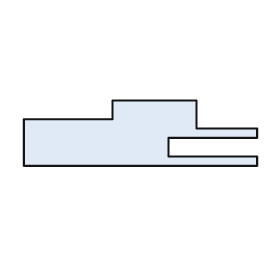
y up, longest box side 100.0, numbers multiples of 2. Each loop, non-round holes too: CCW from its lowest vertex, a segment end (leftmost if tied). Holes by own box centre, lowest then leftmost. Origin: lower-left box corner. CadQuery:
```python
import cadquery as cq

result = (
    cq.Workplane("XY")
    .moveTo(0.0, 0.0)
    .lineTo(100.0, 0.0)
    .lineTo(100.0, 4.0)
    .lineTo(62.0, 4.0)
    .lineTo(62.0, 12.0)
    .lineTo(100.0, 12.0)
    .lineTo(100.0, 16.0)
    .lineTo(74.0, 16.0)
    .lineTo(74.0, 28.0)
    .lineTo(38.0, 28.0)
    .lineTo(38.0, 20.0)
    .lineTo(0.0, 20.0)
    .close()
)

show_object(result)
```